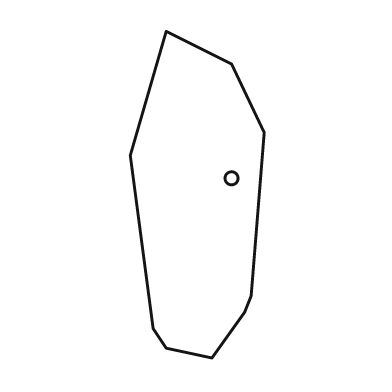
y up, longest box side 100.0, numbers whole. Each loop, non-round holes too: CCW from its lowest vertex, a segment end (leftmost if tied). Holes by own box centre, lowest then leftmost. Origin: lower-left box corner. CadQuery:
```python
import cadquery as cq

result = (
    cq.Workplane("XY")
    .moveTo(25.0, 0.0)
    .lineTo(35.0, 14.0)
    .lineTo(37.0, 19.0)
    .lineTo(41.0, 69.0)
    .lineTo(31.0, 90.0)
    .lineTo(11.0, 100.0)
    .lineTo(0.0, 62.0)
    .lineTo(7.0, 9.0)
    .lineTo(11.0, 3.0)
    .close()
    .moveTo(31.0, 55.0)
    .circle(2.0)
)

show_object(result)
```